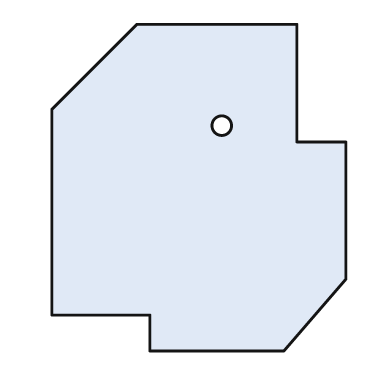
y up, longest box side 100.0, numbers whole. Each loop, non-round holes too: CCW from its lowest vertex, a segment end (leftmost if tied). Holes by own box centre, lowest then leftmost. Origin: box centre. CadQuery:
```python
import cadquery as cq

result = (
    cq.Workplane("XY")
    .moveTo(-15.0, -50.0)
    .lineTo(26.0, -50.0)
    .lineTo(45.0, -28.0)
    .lineTo(45.0, 14.0)
    .lineTo(30.0, 14.0)
    .lineTo(30.0, 50.0)
    .lineTo(-19.0, 50.0)
    .lineTo(-45.0, 24.0)
    .lineTo(-45.0, -39.0)
    .lineTo(-15.0, -39.0)
    .close()
    .moveTo(7.0, 19.0)
    .circle(3.0)
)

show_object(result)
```